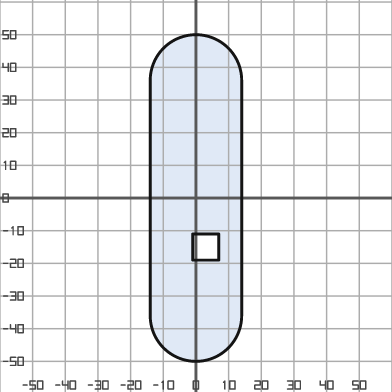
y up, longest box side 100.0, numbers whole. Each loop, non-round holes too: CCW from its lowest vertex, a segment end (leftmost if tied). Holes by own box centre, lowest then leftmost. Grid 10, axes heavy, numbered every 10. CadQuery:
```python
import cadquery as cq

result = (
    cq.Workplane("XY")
    .moveTo(-14.0, -36.0)
    .threePointArc((0.0, -50.0), (14.0, -36.0))
    .lineTo(14.0, 36.0)
    .threePointArc((0.0, 50.0), (-14.0, 36.0))
    .close()
    .moveTo(-1.0, -19.0)
    .lineTo(7.0, -19.0)
    .lineTo(7.0, -11.0)
    .lineTo(-1.0, -11.0)
    .close()
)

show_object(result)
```